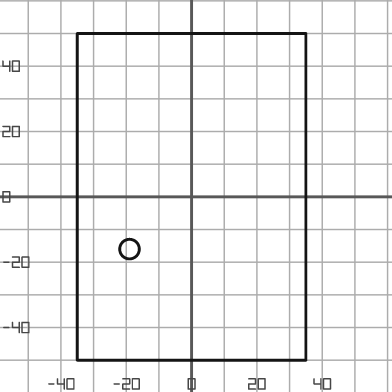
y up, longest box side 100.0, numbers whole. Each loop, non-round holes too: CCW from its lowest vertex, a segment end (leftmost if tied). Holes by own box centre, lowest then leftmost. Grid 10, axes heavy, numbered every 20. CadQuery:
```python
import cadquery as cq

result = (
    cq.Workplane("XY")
    .moveTo(-35.0, -50.0)
    .lineTo(35.0, -50.0)
    .lineTo(35.0, 50.0)
    .lineTo(-35.0, 50.0)
    .close()
    .moveTo(-19.0, -16.0)
    .circle(3.0)
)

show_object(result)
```